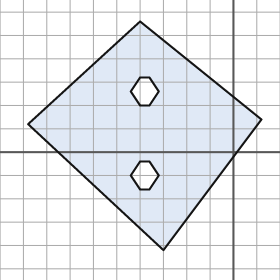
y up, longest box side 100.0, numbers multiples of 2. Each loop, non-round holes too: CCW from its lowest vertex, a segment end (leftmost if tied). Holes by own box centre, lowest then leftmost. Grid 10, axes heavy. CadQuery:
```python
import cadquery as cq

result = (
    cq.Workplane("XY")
    .moveTo(-30.0, -42.0)
    .lineTo(12.0, 14.0)
    .lineTo(-40.0, 56.0)
    .lineTo(-88.0, 12.0)
    .close()
    .moveTo(-40.0, -16.0)
    .lineTo(-36.0, -16.0)
    .lineTo(-32.0, -10.0)
    .lineTo(-36.0, -4.0)
    .lineTo(-40.0, -4.0)
    .lineTo(-44.0, -10.0)
    .close()
    .moveTo(-40.0, 20.0)
    .lineTo(-36.0, 20.0)
    .lineTo(-32.0, 26.0)
    .lineTo(-36.0, 32.0)
    .lineTo(-40.0, 32.0)
    .lineTo(-44.0, 26.0)
    .close()
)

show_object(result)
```